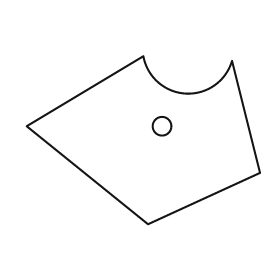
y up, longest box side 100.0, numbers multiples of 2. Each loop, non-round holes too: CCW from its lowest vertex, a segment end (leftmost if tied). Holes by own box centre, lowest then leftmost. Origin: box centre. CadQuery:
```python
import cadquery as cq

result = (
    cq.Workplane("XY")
    .moveTo(2.0, -36.0)
    .lineTo(50.0, -14.0)
    .lineTo(38.0, 34.0)
    .threePointArc((18.0, 20.0), (0.0, 36.0))
    .lineTo(-50.0, 6.0)
    .close()
    .moveTo(8.0, 6.0)
    .circle(4.0)
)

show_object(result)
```